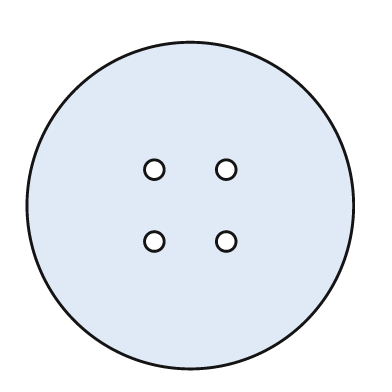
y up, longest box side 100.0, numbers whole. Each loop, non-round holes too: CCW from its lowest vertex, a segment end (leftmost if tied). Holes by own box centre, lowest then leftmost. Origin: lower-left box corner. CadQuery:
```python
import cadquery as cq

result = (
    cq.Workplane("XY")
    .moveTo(50.0, 50.0)
    .circle(50.0)
    .moveTo(39.0, 39.0)
    .circle(3.0)
    .moveTo(61.0, 39.0)
    .circle(3.0)
    .moveTo(39.0, 61.0)
    .circle(3.0)
    .moveTo(61.0, 61.0)
    .circle(3.0)
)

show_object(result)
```